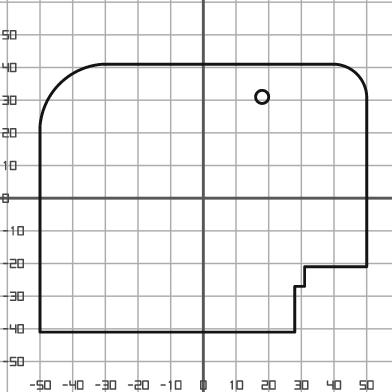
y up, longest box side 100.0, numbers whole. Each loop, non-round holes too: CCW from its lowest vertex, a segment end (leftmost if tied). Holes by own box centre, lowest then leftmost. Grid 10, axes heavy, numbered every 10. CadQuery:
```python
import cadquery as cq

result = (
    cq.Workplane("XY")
    .moveTo(-50.0, -41.0)
    .lineTo(28.0, -41.0)
    .lineTo(28.0, -27.0)
    .lineTo(31.0, -27.0)
    .lineTo(31.0, -21.0)
    .lineTo(50.0, -21.0)
    .lineTo(50.0, 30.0)
    .threePointArc((47.0, 38.0), (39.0, 41.0))
    .lineTo(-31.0, 41.0)
    .threePointArc((-44.0, 35.0), (-50.0, 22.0))
    .close()
    .moveTo(18.0, 31.0)
    .circle(2.0)
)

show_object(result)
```